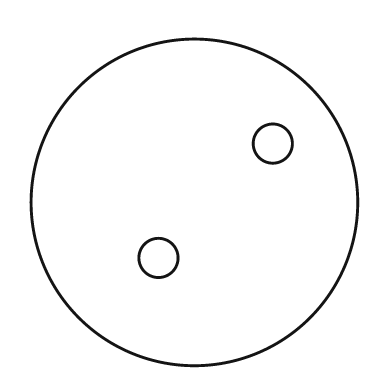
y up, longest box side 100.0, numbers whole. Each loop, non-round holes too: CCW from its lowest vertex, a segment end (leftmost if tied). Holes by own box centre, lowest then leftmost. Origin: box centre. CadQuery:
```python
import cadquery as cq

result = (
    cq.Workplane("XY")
    .moveTo(0.0, 0.0)
    .circle(50.0)
    .moveTo(-11.0, -17.0)
    .circle(6.0)
    .moveTo(24.0, 18.0)
    .circle(6.0)
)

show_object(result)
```